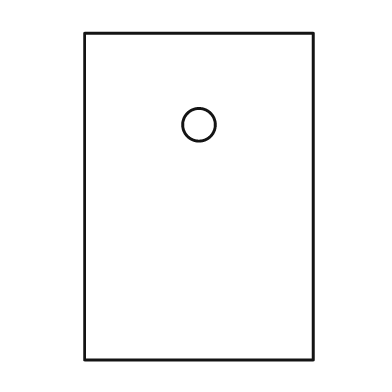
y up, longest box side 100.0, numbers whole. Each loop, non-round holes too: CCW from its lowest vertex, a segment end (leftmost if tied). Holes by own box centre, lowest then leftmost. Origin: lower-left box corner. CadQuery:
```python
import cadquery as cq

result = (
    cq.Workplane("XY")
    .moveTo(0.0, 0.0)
    .lineTo(70.0, 0.0)
    .lineTo(70.0, 100.0)
    .lineTo(0.0, 100.0)
    .close()
    .moveTo(35.0, 72.0)
    .circle(5.0)
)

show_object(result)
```